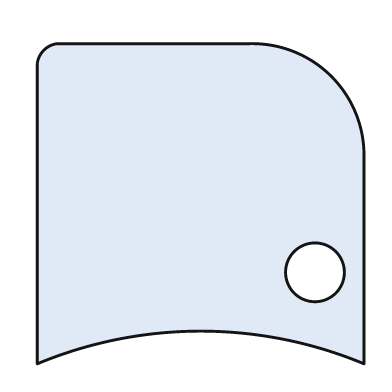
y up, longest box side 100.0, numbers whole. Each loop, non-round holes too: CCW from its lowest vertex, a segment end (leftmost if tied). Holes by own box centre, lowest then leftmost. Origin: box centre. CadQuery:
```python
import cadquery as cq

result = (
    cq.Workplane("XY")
    .moveTo(-50.0, -49.0)
    .threePointArc((0.0, -39.0), (50.0, -49.0))
    .lineTo(50.0, 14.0)
    .threePointArc((40.0, 39.0), (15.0, 49.0))
    .lineTo(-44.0, 49.0)
    .threePointArc((-48.0, 47.0), (-50.0, 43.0))
    .close()
    .moveTo(35.0, -21.0)
    .circle(9.0)
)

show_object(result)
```